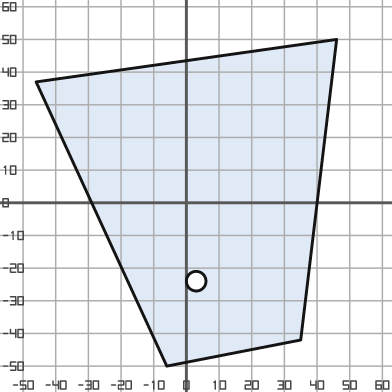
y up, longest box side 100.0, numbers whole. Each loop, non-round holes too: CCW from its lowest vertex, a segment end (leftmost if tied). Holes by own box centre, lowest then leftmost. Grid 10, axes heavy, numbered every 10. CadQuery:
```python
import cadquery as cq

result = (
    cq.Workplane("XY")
    .moveTo(-6.0, -50.0)
    .lineTo(35.0, -42.0)
    .lineTo(46.0, 50.0)
    .lineTo(-46.0, 37.0)
    .close()
    .moveTo(3.0, -24.0)
    .circle(3.0)
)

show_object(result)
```